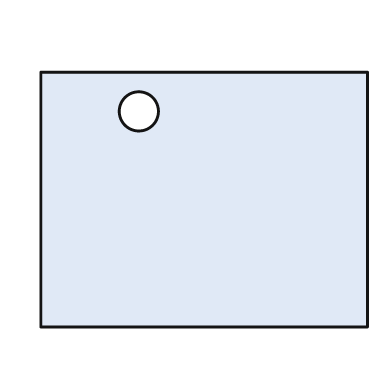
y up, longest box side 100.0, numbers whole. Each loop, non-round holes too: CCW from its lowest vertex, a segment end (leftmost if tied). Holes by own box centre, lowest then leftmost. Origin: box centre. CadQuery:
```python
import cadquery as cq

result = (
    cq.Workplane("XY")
    .moveTo(-50.0, -39.0)
    .lineTo(50.0, -39.0)
    .lineTo(50.0, 39.0)
    .lineTo(-50.0, 39.0)
    .close()
    .moveTo(-20.0, 27.0)
    .circle(6.0)
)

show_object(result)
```